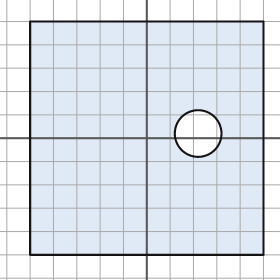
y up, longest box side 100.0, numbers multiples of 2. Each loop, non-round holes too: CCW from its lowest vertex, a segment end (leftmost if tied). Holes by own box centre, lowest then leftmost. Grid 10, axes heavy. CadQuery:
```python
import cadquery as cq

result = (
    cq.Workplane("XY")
    .moveTo(-50.0, -50.0)
    .lineTo(50.0, -50.0)
    .lineTo(50.0, 50.0)
    .lineTo(-50.0, 50.0)
    .close()
    .moveTo(22.0, 2.0)
    .circle(10.0)
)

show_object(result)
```